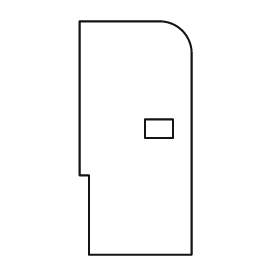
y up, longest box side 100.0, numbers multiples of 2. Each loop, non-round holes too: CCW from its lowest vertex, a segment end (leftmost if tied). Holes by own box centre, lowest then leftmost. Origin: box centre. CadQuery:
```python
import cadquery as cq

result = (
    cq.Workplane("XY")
    .moveTo(-20.0, -50.0)
    .lineTo(24.0, -50.0)
    .lineTo(24.0, 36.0)
    .threePointArc((20.0, 46.0), (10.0, 50.0))
    .lineTo(-24.0, 50.0)
    .lineTo(-24.0, -16.0)
    .lineTo(-20.0, -16.0)
    .close()
    .moveTo(4.0, 0.0)
    .lineTo(16.0, 0.0)
    .lineTo(16.0, 8.0)
    .lineTo(4.0, 8.0)
    .close()
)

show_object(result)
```